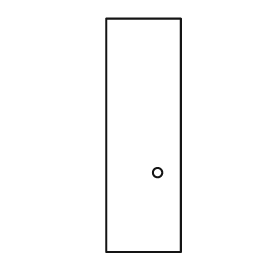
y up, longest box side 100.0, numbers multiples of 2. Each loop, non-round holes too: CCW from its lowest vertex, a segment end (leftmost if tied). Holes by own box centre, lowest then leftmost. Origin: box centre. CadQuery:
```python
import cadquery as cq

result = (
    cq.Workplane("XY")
    .moveTo(-16.0, -50.0)
    .lineTo(16.0, -50.0)
    .lineTo(16.0, 50.0)
    .lineTo(-16.0, 50.0)
    .close()
    .moveTo(6.0, -16.0)
    .circle(2.0)
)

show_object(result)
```